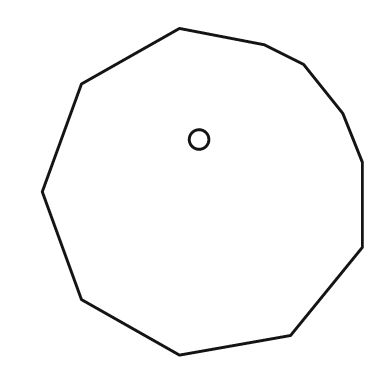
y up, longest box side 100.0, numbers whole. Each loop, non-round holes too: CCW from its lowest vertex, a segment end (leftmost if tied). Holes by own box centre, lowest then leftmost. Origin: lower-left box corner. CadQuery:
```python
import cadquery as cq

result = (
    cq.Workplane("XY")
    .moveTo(42.0, 0.0)
    .lineTo(76.0, 6.0)
    .lineTo(98.0, 33.0)
    .lineTo(98.0, 59.0)
    .lineTo(92.0, 74.0)
    .lineTo(80.0, 89.0)
    .lineTo(68.0, 95.0)
    .lineTo(42.0, 100.0)
    .lineTo(12.0, 83.0)
    .lineTo(0.0, 50.0)
    .lineTo(12.0, 17.0)
    .close()
    .moveTo(48.0, 66.0)
    .circle(3.0)
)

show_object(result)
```